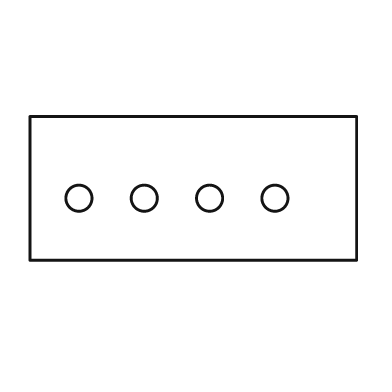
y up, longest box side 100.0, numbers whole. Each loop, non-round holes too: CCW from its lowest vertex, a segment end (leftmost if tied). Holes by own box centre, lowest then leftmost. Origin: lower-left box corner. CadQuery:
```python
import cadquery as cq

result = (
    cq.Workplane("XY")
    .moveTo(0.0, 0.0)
    .lineTo(100.0, 0.0)
    .lineTo(100.0, 44.0)
    .lineTo(0.0, 44.0)
    .close()
    .moveTo(15.0, 19.0)
    .circle(4.0)
    .moveTo(35.0, 19.0)
    .circle(4.0)
    .moveTo(55.0, 19.0)
    .circle(4.0)
    .moveTo(75.0, 19.0)
    .circle(4.0)
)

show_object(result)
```